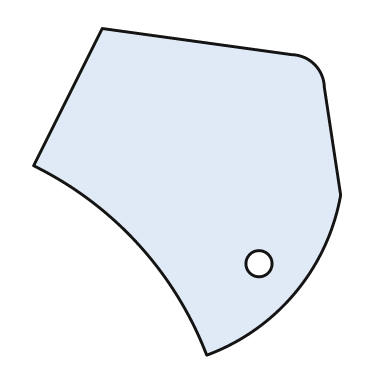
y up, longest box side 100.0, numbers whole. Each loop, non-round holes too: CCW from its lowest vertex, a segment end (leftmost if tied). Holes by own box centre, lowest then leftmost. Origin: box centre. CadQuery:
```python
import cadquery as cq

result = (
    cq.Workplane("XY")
    .moveTo(6.0, -50.0)
    .threePointArc((33.0, -31.0), (47.0, -1.0))
    .lineTo(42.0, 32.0)
    .threePointArc((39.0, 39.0), (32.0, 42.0))
    .lineTo(-26.0, 50.0)
    .lineTo(-47.0, 8.0)
    .threePointArc((-15.0, -16.0), (6.0, -50.0))
    .close()
    .moveTo(22.0, -22.0)
    .circle(4.0)
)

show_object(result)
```